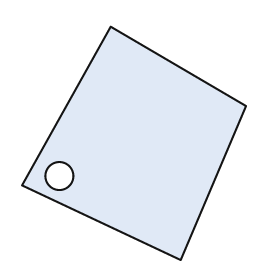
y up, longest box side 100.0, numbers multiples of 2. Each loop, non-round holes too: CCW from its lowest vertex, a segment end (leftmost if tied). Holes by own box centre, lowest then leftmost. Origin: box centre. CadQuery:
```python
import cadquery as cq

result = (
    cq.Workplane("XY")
    .moveTo(20.0, -50.0)
    .lineTo(48.0, 16.0)
    .lineTo(-10.0, 50.0)
    .lineTo(-48.0, -18.0)
    .close()
    .moveTo(-32.0, -14.0)
    .circle(6.0)
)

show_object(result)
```